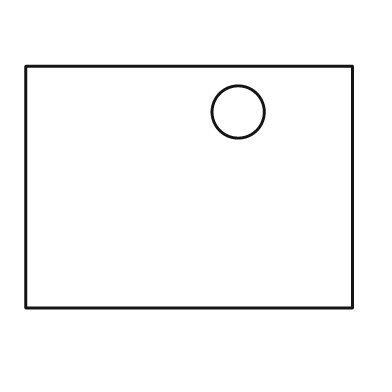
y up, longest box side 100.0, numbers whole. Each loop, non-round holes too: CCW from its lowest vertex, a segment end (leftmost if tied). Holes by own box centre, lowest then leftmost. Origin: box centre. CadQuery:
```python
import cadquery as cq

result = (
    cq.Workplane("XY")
    .moveTo(-50.0, -37.0)
    .lineTo(50.0, -37.0)
    .lineTo(50.0, 37.0)
    .lineTo(-50.0, 37.0)
    .close()
    .moveTo(15.0, 23.0)
    .circle(8.0)
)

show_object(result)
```